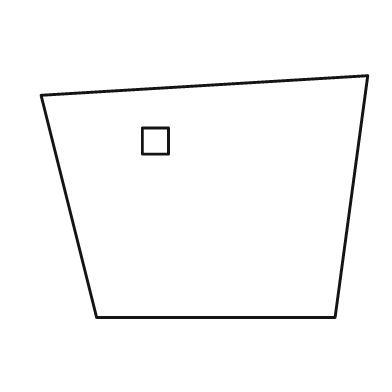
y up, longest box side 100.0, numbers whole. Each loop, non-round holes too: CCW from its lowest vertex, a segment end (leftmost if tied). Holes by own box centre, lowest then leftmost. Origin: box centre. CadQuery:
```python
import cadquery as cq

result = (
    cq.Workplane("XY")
    .moveTo(-33.0, -37.0)
    .lineTo(40.0, -37.0)
    .lineTo(50.0, 37.0)
    .lineTo(-50.0, 31.0)
    .close()
    .moveTo(-19.0, 13.0)
    .lineTo(-11.0, 13.0)
    .lineTo(-11.0, 21.0)
    .lineTo(-19.0, 21.0)
    .close()
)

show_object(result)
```